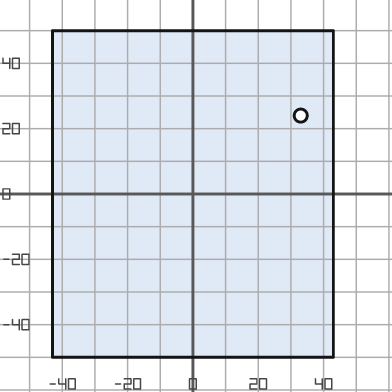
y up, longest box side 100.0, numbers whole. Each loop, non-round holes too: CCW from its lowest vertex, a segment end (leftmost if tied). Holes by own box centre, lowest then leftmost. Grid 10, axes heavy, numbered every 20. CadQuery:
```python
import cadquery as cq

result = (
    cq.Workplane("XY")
    .moveTo(-43.0, -50.0)
    .lineTo(43.0, -50.0)
    .lineTo(43.0, 50.0)
    .lineTo(-43.0, 50.0)
    .close()
    .moveTo(33.0, 24.0)
    .circle(2.0)
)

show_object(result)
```